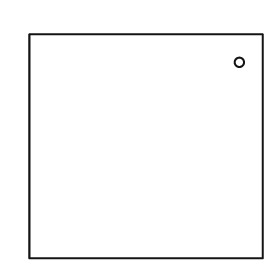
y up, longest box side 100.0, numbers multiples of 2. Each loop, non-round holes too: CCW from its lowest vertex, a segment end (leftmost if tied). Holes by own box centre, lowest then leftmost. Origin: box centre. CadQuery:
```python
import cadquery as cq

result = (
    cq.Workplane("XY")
    .moveTo(-50.0, -48.0)
    .lineTo(50.0, -48.0)
    .lineTo(50.0, 48.0)
    .lineTo(-50.0, 48.0)
    .close()
    .moveTo(40.0, 36.0)
    .circle(2.0)
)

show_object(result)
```